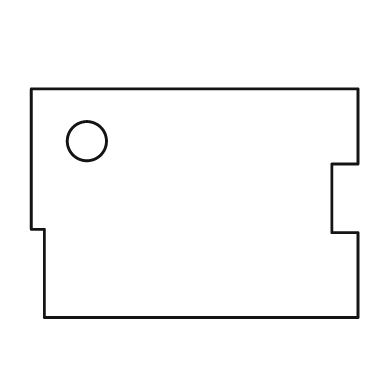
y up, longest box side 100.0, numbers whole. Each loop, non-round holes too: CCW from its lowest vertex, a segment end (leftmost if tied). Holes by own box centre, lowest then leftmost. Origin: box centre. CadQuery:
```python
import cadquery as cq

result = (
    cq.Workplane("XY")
    .moveTo(-46.0, -35.0)
    .lineTo(50.0, -35.0)
    .lineTo(50.0, -9.0)
    .lineTo(42.0, -9.0)
    .lineTo(42.0, 12.0)
    .lineTo(50.0, 12.0)
    .lineTo(50.0, 35.0)
    .lineTo(-50.0, 35.0)
    .lineTo(-50.0, -8.0)
    .lineTo(-46.0, -8.0)
    .close()
    .moveTo(-33.0, 19.0)
    .circle(6.0)
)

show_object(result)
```